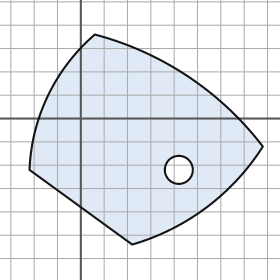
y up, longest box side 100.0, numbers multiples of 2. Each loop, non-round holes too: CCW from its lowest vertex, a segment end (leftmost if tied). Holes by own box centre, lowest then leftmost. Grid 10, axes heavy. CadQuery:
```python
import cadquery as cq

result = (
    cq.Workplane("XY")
    .moveTo(22.0, -54.0)
    .threePointArc((54.0, -38.0), (78.0, -12.0))
    .threePointArc((46.0, 18.0), (6.0, 36.0))
    .threePointArc((-14.0, 10.0), (-22.0, -22.0))
    .close()
    .moveTo(42.0, -22.0)
    .circle(6.0)
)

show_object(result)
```